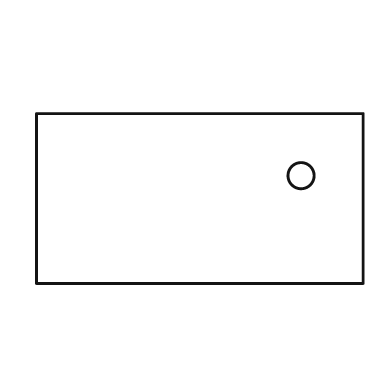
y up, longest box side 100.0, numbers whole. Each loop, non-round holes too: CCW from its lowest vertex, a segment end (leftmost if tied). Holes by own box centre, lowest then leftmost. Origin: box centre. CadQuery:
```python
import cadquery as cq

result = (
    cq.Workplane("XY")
    .moveTo(-50.0, -26.0)
    .lineTo(50.0, -26.0)
    .lineTo(50.0, 26.0)
    .lineTo(-50.0, 26.0)
    .close()
    .moveTo(31.0, 7.0)
    .circle(4.0)
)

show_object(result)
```